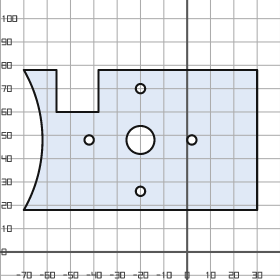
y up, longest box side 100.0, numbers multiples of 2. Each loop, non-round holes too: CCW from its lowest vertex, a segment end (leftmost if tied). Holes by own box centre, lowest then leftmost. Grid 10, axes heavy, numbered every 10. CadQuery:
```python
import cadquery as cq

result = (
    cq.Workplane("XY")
    .moveTo(-70.0, 18.0)
    .lineTo(30.0, 18.0)
    .lineTo(30.0, 78.0)
    .lineTo(-38.0, 78.0)
    .lineTo(-38.0, 60.0)
    .lineTo(-56.0, 60.0)
    .lineTo(-56.0, 78.0)
    .lineTo(-70.0, 78.0)
    .threePointArc((-62.0, 48.0), (-70.0, 18.0))
    .close()
    .moveTo(-20.0, 26.0)
    .circle(2.0)
    .moveTo(-42.0, 48.0)
    .circle(2.0)
    .moveTo(-20.0, 48.0)
    .circle(6.0)
    .moveTo(2.0, 48.0)
    .circle(2.0)
    .moveTo(-20.0, 70.0)
    .circle(2.0)
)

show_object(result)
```